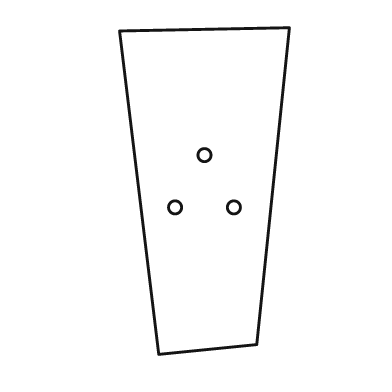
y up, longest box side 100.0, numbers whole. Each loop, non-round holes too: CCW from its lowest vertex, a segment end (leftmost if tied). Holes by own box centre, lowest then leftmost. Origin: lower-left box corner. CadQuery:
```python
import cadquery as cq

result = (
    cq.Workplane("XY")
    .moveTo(12.0, 0.0)
    .lineTo(42.0, 3.0)
    .lineTo(52.0, 100.0)
    .lineTo(0.0, 99.0)
    .close()
    .moveTo(17.0, 45.0)
    .circle(2.0)
    .moveTo(35.0, 45.0)
    .circle(2.0)
    .moveTo(26.0, 61.0)
    .circle(2.0)
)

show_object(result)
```